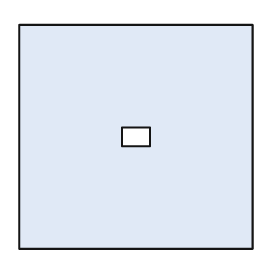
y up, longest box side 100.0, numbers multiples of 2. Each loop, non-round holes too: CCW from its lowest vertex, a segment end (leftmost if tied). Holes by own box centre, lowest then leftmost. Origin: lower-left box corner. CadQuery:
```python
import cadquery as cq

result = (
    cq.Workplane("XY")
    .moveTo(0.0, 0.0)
    .lineTo(100.0, 0.0)
    .lineTo(100.0, 96.0)
    .lineTo(0.0, 96.0)
    .close()
    .moveTo(44.0, 44.0)
    .lineTo(56.0, 44.0)
    .lineTo(56.0, 52.0)
    .lineTo(44.0, 52.0)
    .close()
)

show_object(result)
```